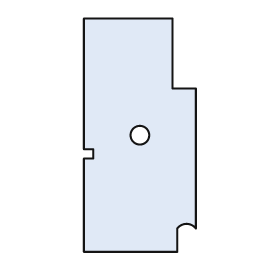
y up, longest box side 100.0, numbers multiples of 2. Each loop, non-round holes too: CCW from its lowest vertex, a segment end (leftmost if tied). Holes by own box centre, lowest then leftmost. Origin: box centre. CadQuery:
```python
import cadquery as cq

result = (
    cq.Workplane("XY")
    .moveTo(-24.0, -50.0)
    .lineTo(16.0, -50.0)
    .lineTo(16.0, -40.0)
    .threePointArc((20.0, -38.0), (24.0, -40.0))
    .lineTo(24.0, 20.0)
    .lineTo(14.0, 20.0)
    .lineTo(14.0, 50.0)
    .lineTo(-24.0, 50.0)
    .lineTo(-24.0, -6.0)
    .lineTo(-20.0, -6.0)
    .lineTo(-20.0, -10.0)
    .lineTo(-24.0, -10.0)
    .close()
    .moveTo(0.0, 0.0)
    .circle(4.0)
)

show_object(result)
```